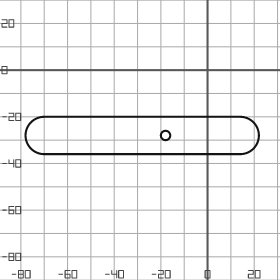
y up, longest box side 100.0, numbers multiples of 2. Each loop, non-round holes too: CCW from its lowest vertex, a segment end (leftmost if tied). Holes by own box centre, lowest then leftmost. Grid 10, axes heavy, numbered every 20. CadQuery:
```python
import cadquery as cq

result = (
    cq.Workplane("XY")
    .moveTo(-70.0, -36.0)
    .lineTo(14.0, -36.0)
    .threePointArc((22.0, -28.0), (14.0, -20.0))
    .lineTo(-70.0, -20.0)
    .threePointArc((-78.0, -28.0), (-70.0, -36.0))
    .close()
    .moveTo(-18.0, -28.0)
    .circle(2.0)
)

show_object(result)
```